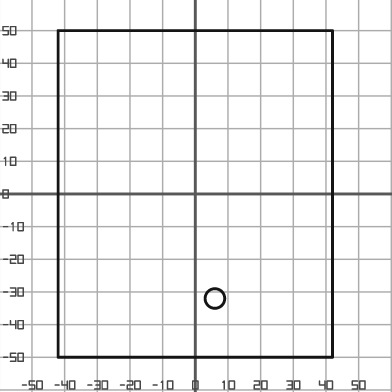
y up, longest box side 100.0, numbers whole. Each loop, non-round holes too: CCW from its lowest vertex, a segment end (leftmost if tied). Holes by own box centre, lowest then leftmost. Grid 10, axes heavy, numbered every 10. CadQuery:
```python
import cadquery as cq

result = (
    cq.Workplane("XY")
    .moveTo(-42.0, -50.0)
    .lineTo(42.0, -50.0)
    .lineTo(42.0, 50.0)
    .lineTo(-42.0, 50.0)
    .close()
    .moveTo(6.0, -32.0)
    .circle(3.0)
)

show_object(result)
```